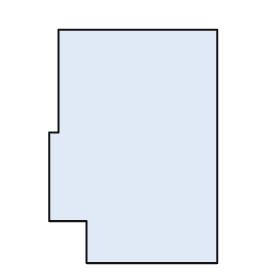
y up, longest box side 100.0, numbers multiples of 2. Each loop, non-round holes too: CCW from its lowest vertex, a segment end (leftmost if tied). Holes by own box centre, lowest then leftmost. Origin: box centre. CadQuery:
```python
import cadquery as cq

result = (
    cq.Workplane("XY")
    .moveTo(-20.0, -50.0)
    .lineTo(36.0, -50.0)
    .lineTo(36.0, 50.0)
    .lineTo(-32.0, 50.0)
    .lineTo(-32.0, 6.0)
    .lineTo(-36.0, 6.0)
    .lineTo(-36.0, -32.0)
    .lineTo(-20.0, -32.0)
    .close()
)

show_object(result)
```